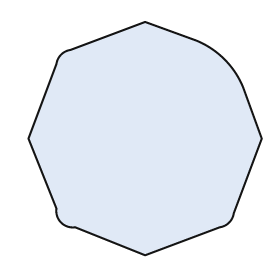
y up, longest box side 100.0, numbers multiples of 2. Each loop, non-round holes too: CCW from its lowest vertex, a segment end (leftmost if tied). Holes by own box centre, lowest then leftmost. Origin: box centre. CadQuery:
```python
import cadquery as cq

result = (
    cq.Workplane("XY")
    .moveTo(0.0, -50.0)
    .lineTo(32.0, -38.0)
    .threePointArc((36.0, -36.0), (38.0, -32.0))
    .lineTo(50.0, 0.0)
    .lineTo(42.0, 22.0)
    .threePointArc((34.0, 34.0), (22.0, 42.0))
    .lineTo(0.0, 50.0)
    .lineTo(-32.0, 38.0)
    .threePointArc((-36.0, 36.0), (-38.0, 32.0))
    .lineTo(-50.0, 0.0)
    .lineTo(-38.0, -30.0)
    .threePointArc((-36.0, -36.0), (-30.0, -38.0))
    .close()
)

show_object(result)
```